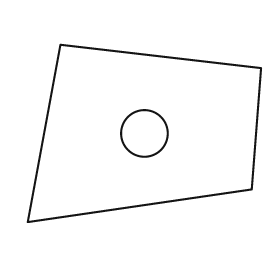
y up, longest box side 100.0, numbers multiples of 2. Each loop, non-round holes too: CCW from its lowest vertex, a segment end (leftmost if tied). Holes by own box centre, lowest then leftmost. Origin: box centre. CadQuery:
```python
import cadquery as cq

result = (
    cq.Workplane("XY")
    .moveTo(-50.0, -38.0)
    .lineTo(46.0, -24.0)
    .lineTo(50.0, 28.0)
    .lineTo(-36.0, 38.0)
    .close()
    .moveTo(0.0, 0.0)
    .circle(10.0)
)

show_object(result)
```